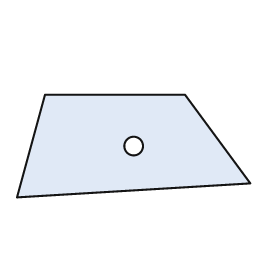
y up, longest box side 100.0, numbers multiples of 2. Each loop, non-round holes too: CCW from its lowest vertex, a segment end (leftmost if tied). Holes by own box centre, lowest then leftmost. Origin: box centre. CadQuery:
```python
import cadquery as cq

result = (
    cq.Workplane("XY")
    .moveTo(-50.0, -22.0)
    .lineTo(50.0, -16.0)
    .lineTo(22.0, 22.0)
    .lineTo(-38.0, 22.0)
    .close()
    .moveTo(0.0, 0.0)
    .circle(4.0)
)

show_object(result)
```